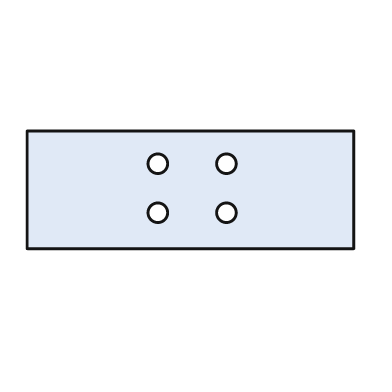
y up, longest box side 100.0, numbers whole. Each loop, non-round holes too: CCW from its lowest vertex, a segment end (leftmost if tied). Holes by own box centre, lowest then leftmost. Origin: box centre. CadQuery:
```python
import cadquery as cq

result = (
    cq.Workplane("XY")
    .moveTo(-50.0, -18.0)
    .lineTo(50.0, -18.0)
    .lineTo(50.0, 18.0)
    .lineTo(-50.0, 18.0)
    .close()
    .moveTo(-10.0, -7.0)
    .circle(3.0)
    .moveTo(11.0, -7.0)
    .circle(3.0)
    .moveTo(-10.0, 8.0)
    .circle(3.0)
    .moveTo(11.0, 8.0)
    .circle(3.0)
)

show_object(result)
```